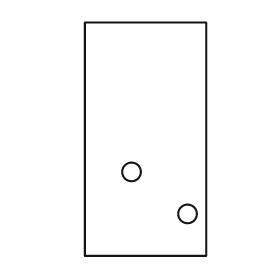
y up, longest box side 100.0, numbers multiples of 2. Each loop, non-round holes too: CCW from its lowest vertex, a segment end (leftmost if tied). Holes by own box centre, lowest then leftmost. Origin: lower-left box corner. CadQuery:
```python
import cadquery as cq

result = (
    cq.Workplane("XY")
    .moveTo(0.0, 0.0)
    .lineTo(52.0, 0.0)
    .lineTo(52.0, 100.0)
    .lineTo(0.0, 100.0)
    .close()
    .moveTo(44.0, 18.0)
    .circle(4.0)
    .moveTo(20.0, 36.0)
    .circle(4.0)
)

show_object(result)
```